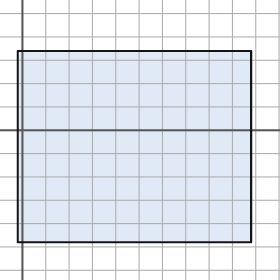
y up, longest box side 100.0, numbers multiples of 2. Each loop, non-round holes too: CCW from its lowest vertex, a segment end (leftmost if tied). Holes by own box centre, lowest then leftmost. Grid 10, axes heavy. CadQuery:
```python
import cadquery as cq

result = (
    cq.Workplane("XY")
    .moveTo(-2.0, -48.0)
    .lineTo(98.0, -48.0)
    .lineTo(98.0, 34.0)
    .lineTo(-2.0, 34.0)
    .close()
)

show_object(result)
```